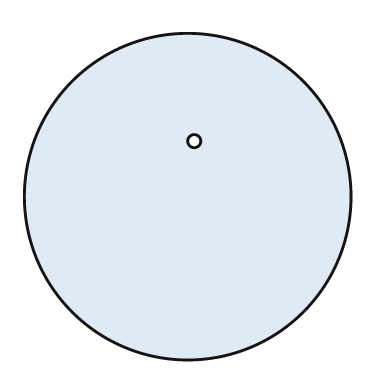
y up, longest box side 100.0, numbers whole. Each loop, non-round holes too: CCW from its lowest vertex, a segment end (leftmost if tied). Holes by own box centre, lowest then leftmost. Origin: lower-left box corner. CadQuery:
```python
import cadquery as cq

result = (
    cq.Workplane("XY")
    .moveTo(50.0, 50.0)
    .circle(50.0)
    .moveTo(52.0, 67.0)
    .circle(2.0)
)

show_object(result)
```